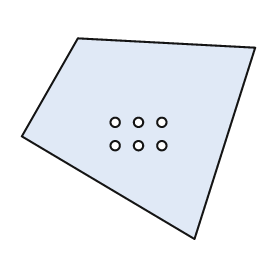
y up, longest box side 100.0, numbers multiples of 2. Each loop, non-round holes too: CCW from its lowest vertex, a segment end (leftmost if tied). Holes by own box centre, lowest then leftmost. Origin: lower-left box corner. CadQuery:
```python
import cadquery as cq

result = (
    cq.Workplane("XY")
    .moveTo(74.0, 0.0)
    .lineTo(100.0, 82.0)
    .lineTo(24.0, 86.0)
    .lineTo(0.0, 44.0)
    .close()
    .moveTo(40.0, 40.0)
    .circle(2.0)
    .moveTo(50.0, 40.0)
    .circle(2.0)
    .moveTo(60.0, 40.0)
    .circle(2.0)
    .moveTo(40.0, 50.0)
    .circle(2.0)
    .moveTo(50.0, 50.0)
    .circle(2.0)
    .moveTo(60.0, 50.0)
    .circle(2.0)
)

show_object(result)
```